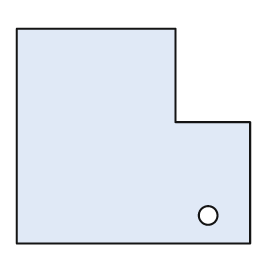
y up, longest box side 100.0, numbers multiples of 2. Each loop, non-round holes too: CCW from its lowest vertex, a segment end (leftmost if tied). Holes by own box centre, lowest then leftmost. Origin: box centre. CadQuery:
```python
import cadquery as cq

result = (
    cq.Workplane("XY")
    .moveTo(-50.0, -46.0)
    .lineTo(50.0, -46.0)
    .lineTo(50.0, 6.0)
    .lineTo(18.0, 6.0)
    .lineTo(18.0, 46.0)
    .lineTo(-50.0, 46.0)
    .close()
    .moveTo(32.0, -34.0)
    .circle(4.0)
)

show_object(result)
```